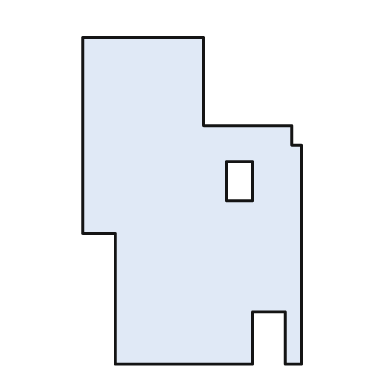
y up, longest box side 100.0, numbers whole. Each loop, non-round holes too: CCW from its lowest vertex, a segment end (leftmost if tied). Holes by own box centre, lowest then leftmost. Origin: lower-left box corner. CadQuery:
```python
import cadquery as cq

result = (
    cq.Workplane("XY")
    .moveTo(10.0, 0.0)
    .lineTo(52.0, 0.0)
    .lineTo(52.0, 16.0)
    .lineTo(62.0, 16.0)
    .lineTo(62.0, 0.0)
    .lineTo(67.0, 0.0)
    .lineTo(67.0, 67.0)
    .lineTo(64.0, 67.0)
    .lineTo(64.0, 73.0)
    .lineTo(37.0, 73.0)
    .lineTo(37.0, 100.0)
    .lineTo(0.0, 100.0)
    .lineTo(0.0, 40.0)
    .lineTo(10.0, 40.0)
    .close()
    .moveTo(44.0, 50.0)
    .lineTo(52.0, 50.0)
    .lineTo(52.0, 62.0)
    .lineTo(44.0, 62.0)
    .close()
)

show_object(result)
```